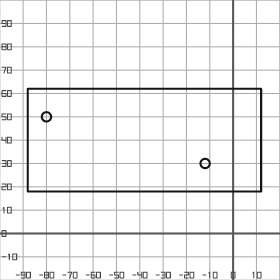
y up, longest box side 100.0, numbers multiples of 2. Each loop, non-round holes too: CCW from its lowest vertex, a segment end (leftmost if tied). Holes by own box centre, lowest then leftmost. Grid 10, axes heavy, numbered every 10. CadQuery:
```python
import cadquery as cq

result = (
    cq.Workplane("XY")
    .moveTo(-88.0, 18.0)
    .lineTo(12.0, 18.0)
    .lineTo(12.0, 62.0)
    .lineTo(-88.0, 62.0)
    .close()
    .moveTo(-12.0, 30.0)
    .circle(2.0)
    .moveTo(-80.0, 50.0)
    .circle(2.0)
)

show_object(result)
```